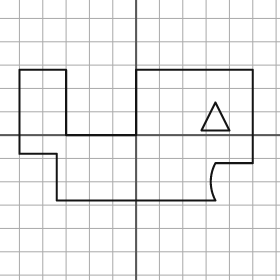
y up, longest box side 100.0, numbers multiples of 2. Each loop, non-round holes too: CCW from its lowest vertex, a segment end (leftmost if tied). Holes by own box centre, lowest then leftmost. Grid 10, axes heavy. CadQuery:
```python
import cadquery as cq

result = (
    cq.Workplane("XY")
    .moveTo(-34.0, -28.0)
    .lineTo(34.0, -28.0)
    .threePointArc((32.0, -20.0), (34.0, -12.0))
    .lineTo(50.0, -12.0)
    .lineTo(50.0, 28.0)
    .lineTo(0.0, 28.0)
    .lineTo(0.0, 0.0)
    .lineTo(-30.0, 0.0)
    .lineTo(-30.0, 28.0)
    .lineTo(-50.0, 28.0)
    .lineTo(-50.0, -8.0)
    .lineTo(-34.0, -8.0)
    .close()
    .moveTo(28.0, 2.0)
    .lineTo(40.0, 2.0)
    .lineTo(34.0, 14.0)
    .close()
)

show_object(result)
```